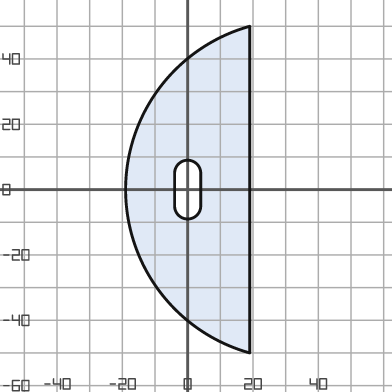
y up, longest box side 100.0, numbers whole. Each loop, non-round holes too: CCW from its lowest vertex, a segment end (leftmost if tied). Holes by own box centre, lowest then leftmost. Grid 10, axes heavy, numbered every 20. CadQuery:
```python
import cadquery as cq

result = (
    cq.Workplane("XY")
    .moveTo(19.0, -50.0)
    .lineTo(19.0, 50.0)
    .threePointArc((-19.0, 0.0), (19.0, -50.0))
    .close()
    .moveTo(-4.0, -5.0)
    .threePointArc((0.0, -9.0), (4.0, -5.0))
    .lineTo(4.0, 5.0)
    .threePointArc((0.0, 9.0), (-4.0, 5.0))
    .close()
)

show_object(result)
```